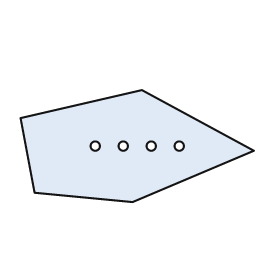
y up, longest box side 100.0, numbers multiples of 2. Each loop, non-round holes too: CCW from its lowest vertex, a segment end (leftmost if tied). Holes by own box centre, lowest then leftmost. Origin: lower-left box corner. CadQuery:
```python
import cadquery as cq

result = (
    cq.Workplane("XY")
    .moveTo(48.0, 0.0)
    .lineTo(100.0, 22.0)
    .lineTo(52.0, 48.0)
    .lineTo(0.0, 36.0)
    .lineTo(6.0, 4.0)
    .close()
    .moveTo(32.0, 24.0)
    .circle(2.0)
    .moveTo(44.0, 24.0)
    .circle(2.0)
    .moveTo(56.0, 24.0)
    .circle(2.0)
    .moveTo(68.0, 24.0)
    .circle(2.0)
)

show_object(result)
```